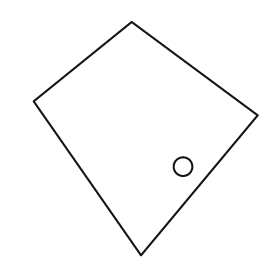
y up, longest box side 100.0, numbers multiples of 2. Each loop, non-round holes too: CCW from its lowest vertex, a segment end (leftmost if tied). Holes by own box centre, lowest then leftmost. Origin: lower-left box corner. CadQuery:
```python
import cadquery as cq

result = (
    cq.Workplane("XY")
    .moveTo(46.0, 0.0)
    .lineTo(96.0, 60.0)
    .lineTo(42.0, 100.0)
    .lineTo(0.0, 66.0)
    .close()
    .moveTo(64.0, 38.0)
    .circle(4.0)
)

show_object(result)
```